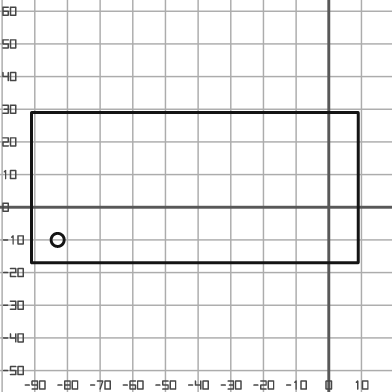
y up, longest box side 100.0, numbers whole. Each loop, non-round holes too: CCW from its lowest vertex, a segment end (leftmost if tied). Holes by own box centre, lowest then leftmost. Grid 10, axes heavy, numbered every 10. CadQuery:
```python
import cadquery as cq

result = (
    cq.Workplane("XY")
    .moveTo(-91.0, -17.0)
    .lineTo(9.0, -17.0)
    .lineTo(9.0, 29.0)
    .lineTo(-91.0, 29.0)
    .close()
    .moveTo(-83.0, -10.0)
    .circle(2.0)
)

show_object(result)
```